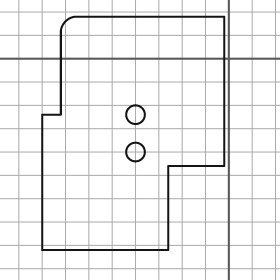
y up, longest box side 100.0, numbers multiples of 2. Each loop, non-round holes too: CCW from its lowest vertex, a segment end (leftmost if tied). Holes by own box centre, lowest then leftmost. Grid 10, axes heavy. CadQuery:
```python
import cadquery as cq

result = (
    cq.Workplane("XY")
    .moveTo(-80.0, -82.0)
    .lineTo(-26.0, -82.0)
    .lineTo(-26.0, -46.0)
    .lineTo(-2.0, -46.0)
    .lineTo(-2.0, 18.0)
    .lineTo(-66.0, 18.0)
    .threePointArc((-70.0, 16.0), (-72.0, 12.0))
    .lineTo(-72.0, -24.0)
    .lineTo(-80.0, -24.0)
    .close()
    .moveTo(-40.0, -40.0)
    .circle(4.0)
    .moveTo(-40.0, -24.0)
    .circle(4.0)
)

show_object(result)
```